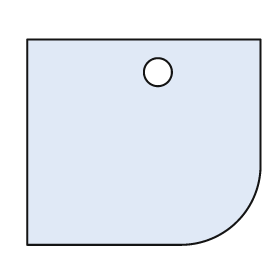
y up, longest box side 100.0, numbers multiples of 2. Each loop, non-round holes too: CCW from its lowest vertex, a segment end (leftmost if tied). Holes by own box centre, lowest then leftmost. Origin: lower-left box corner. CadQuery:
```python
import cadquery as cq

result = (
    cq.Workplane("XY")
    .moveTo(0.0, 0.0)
    .lineTo(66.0, 0.0)
    .threePointArc((90.0, 10.0), (100.0, 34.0))
    .lineTo(100.0, 88.0)
    .lineTo(0.0, 88.0)
    .close()
    .moveTo(56.0, 74.0)
    .circle(6.0)
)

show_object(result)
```